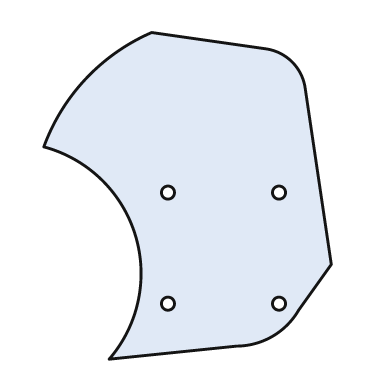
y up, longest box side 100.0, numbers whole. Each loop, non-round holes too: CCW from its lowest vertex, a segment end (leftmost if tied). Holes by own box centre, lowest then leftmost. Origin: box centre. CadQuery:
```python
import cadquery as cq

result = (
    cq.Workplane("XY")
    .moveTo(-24.0, -50.0)
    .lineTo(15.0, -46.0)
    .threePointArc((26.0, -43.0), (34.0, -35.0))
    .lineTo(44.0, -21.0)
    .lineTo(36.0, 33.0)
    .threePointArc((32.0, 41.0), (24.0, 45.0))
    .lineTo(-11.0, 50.0)
    .threePointArc((-31.0, 36.0), (-44.0, 15.0))
    .threePointArc((-16.0, -12.0), (-24.0, -50.0))
    .close()
    .moveTo(-6.0, -33.0)
    .circle(2.0)
    .moveTo(28.0, -33.0)
    .circle(2.0)
    .moveTo(-6.0, 1.0)
    .circle(2.0)
    .moveTo(28.0, 1.0)
    .circle(2.0)
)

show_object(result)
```